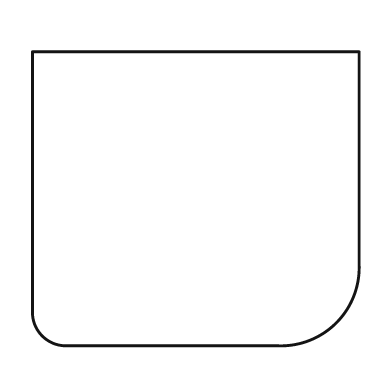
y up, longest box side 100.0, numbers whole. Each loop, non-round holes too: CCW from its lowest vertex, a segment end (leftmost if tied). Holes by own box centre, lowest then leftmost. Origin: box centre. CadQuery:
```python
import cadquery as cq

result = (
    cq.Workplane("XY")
    .moveTo(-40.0, -45.0)
    .lineTo(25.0, -45.0)
    .threePointArc((43.0, -38.0), (50.0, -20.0))
    .lineTo(50.0, 45.0)
    .lineTo(-50.0, 45.0)
    .lineTo(-50.0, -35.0)
    .threePointArc((-47.0, -42.0), (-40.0, -45.0))
    .close()
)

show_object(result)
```